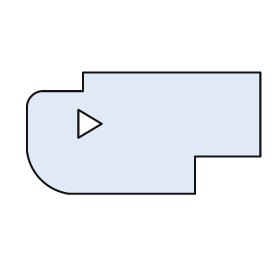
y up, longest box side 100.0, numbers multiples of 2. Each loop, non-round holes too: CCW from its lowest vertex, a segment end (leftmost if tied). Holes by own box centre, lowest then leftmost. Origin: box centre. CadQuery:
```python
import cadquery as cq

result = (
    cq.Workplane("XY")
    .moveTo(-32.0, -26.0)
    .lineTo(22.0, -26.0)
    .lineTo(22.0, -10.0)
    .lineTo(50.0, -10.0)
    .lineTo(50.0, 26.0)
    .lineTo(-26.0, 26.0)
    .lineTo(-26.0, 18.0)
    .lineTo(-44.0, 18.0)
    .threePointArc((-48.0, 16.0), (-50.0, 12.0))
    .lineTo(-50.0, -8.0)
    .threePointArc((-44.0, -20.0), (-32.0, -26.0))
    .close()
    .moveTo(-28.0, -2.0)
    .lineTo(-18.0, 4.0)
    .lineTo(-28.0, 10.0)
    .close()
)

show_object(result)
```